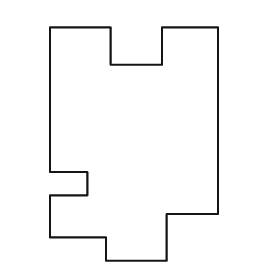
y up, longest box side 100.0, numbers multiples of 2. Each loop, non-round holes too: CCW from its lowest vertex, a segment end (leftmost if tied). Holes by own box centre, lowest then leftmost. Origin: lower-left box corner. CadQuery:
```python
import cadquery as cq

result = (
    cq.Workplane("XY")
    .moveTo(24.0, 0.0)
    .lineTo(50.0, 0.0)
    .lineTo(50.0, 20.0)
    .lineTo(72.0, 20.0)
    .lineTo(72.0, 100.0)
    .lineTo(48.0, 100.0)
    .lineTo(48.0, 84.0)
    .lineTo(26.0, 84.0)
    .lineTo(26.0, 100.0)
    .lineTo(0.0, 100.0)
    .lineTo(0.0, 38.0)
    .lineTo(16.0, 38.0)
    .lineTo(16.0, 28.0)
    .lineTo(0.0, 28.0)
    .lineTo(0.0, 10.0)
    .lineTo(24.0, 10.0)
    .close()
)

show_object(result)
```